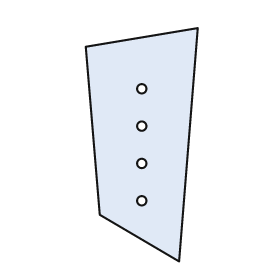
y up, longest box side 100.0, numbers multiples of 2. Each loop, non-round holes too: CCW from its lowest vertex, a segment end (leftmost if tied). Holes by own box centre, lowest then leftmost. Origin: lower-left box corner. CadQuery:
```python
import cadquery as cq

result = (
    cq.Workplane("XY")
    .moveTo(40.0, 0.0)
    .lineTo(48.0, 100.0)
    .lineTo(0.0, 92.0)
    .lineTo(6.0, 20.0)
    .close()
    .moveTo(24.0, 26.0)
    .circle(2.0)
    .moveTo(24.0, 42.0)
    .circle(2.0)
    .moveTo(24.0, 58.0)
    .circle(2.0)
    .moveTo(24.0, 74.0)
    .circle(2.0)
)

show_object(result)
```